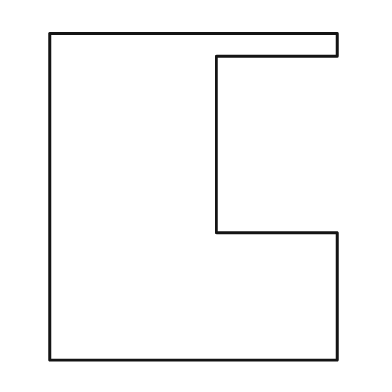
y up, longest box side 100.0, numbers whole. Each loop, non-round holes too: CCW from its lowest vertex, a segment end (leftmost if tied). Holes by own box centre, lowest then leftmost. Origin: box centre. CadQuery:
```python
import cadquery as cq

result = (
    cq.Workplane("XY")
    .moveTo(-44.0, -50.0)
    .lineTo(44.0, -50.0)
    .lineTo(44.0, -11.0)
    .lineTo(7.0, -11.0)
    .lineTo(7.0, 43.0)
    .lineTo(44.0, 43.0)
    .lineTo(44.0, 50.0)
    .lineTo(-44.0, 50.0)
    .close()
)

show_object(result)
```